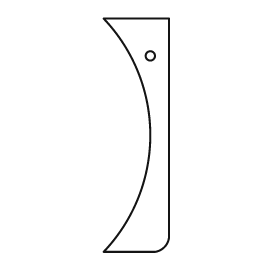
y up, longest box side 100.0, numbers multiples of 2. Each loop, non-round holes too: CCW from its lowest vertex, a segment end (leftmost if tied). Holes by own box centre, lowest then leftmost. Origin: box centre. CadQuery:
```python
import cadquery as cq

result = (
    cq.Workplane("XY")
    .moveTo(-14.0, -50.0)
    .lineTo(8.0, -50.0)
    .threePointArc((12.0, -48.0), (14.0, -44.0))
    .lineTo(14.0, 50.0)
    .lineTo(-14.0, 50.0)
    .threePointArc((6.0, 0.0), (-14.0, -50.0))
    .close()
    .moveTo(6.0, 34.0)
    .circle(2.0)
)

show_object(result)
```